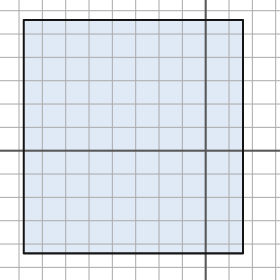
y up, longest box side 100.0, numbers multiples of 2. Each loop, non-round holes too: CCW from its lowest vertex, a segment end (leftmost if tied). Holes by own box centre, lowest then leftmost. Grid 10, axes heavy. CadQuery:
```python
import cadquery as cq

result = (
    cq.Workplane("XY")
    .moveTo(-78.0, -44.0)
    .lineTo(16.0, -44.0)
    .lineTo(16.0, 56.0)
    .lineTo(-78.0, 56.0)
    .close()
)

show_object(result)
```